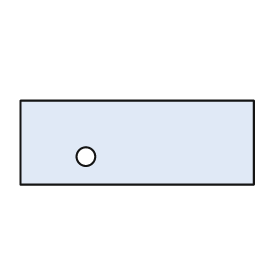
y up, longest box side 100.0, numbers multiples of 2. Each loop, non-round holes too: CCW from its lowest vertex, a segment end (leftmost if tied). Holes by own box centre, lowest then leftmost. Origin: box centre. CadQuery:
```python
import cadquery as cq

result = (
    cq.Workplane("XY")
    .moveTo(-50.0, -18.0)
    .lineTo(50.0, -18.0)
    .lineTo(50.0, 18.0)
    .lineTo(-50.0, 18.0)
    .close()
    .moveTo(-22.0, -6.0)
    .circle(4.0)
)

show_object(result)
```